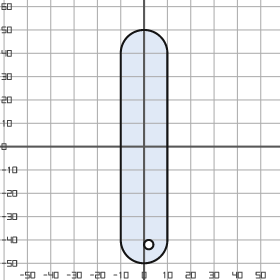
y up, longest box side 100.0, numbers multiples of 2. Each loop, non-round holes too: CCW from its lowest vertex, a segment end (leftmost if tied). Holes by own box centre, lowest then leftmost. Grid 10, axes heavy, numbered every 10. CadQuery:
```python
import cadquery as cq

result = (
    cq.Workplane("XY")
    .moveTo(-10.0, -40.0)
    .threePointArc((0.0, -50.0), (10.0, -40.0))
    .lineTo(10.0, 40.0)
    .threePointArc((0.0, 50.0), (-10.0, 40.0))
    .close()
    .moveTo(2.0, -42.0)
    .circle(2.0)
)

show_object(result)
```